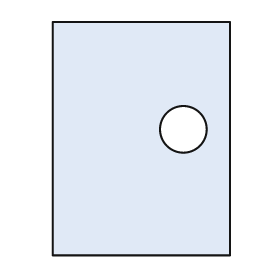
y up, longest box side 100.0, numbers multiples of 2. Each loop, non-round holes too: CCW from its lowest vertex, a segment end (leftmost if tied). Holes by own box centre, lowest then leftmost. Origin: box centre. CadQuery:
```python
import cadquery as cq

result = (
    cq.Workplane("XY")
    .moveTo(-38.0, -50.0)
    .lineTo(38.0, -50.0)
    .lineTo(38.0, 50.0)
    .lineTo(-38.0, 50.0)
    .close()
    .moveTo(18.0, 4.0)
    .circle(10.0)
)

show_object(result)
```